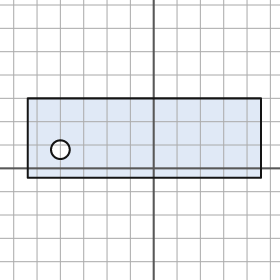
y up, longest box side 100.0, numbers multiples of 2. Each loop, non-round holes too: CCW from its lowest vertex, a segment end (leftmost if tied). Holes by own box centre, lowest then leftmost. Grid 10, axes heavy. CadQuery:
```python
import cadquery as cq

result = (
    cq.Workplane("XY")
    .moveTo(-54.0, -4.0)
    .lineTo(46.0, -4.0)
    .lineTo(46.0, 30.0)
    .lineTo(-54.0, 30.0)
    .close()
    .moveTo(-40.0, 8.0)
    .circle(4.0)
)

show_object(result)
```